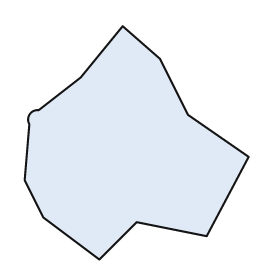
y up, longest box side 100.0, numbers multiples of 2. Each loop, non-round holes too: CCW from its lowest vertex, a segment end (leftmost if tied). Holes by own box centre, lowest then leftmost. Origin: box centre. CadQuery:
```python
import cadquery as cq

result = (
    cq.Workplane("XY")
    .moveTo(-16.0, -50.0)
    .lineTo(0.0, -34.0)
    .lineTo(30.0, -40.0)
    .lineTo(48.0, -6.0)
    .lineTo(22.0, 12.0)
    .lineTo(10.0, 36.0)
    .lineTo(-6.0, 50.0)
    .lineTo(-24.0, 28.0)
    .lineTo(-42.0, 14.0)
    .threePointArc((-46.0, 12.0), (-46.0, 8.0))
    .lineTo(-48.0, -16.0)
    .lineTo(-40.0, -32.0)
    .close()
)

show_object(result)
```